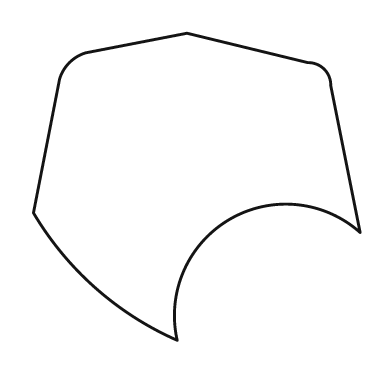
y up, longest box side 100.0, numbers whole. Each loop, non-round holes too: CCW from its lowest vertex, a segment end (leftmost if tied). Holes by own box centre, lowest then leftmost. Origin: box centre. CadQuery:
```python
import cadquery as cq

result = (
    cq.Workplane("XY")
    .moveTo(-6.0, -47.0)
    .threePointArc((10.0, -10.0), (50.0, -14.0))
    .lineTo(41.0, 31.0)
    .threePointArc((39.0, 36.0), (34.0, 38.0))
    .lineTo(-3.0, 47.0)
    .lineTo(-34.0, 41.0)
    .threePointArc((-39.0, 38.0), (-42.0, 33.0))
    .lineTo(-50.0, -8.0)
    .threePointArc((-31.0, -31.0), (-6.0, -47.0))
    .close()
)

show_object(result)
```